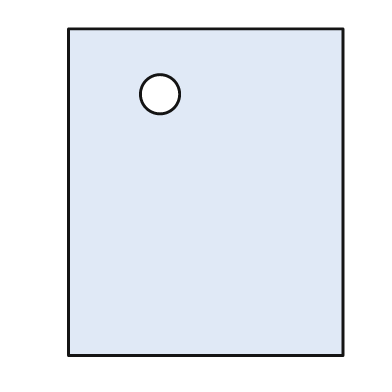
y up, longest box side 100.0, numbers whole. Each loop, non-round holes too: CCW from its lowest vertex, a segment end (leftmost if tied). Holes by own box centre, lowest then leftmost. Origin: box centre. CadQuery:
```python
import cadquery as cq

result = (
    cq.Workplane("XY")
    .moveTo(-42.0, -50.0)
    .lineTo(42.0, -50.0)
    .lineTo(42.0, 50.0)
    .lineTo(-42.0, 50.0)
    .close()
    .moveTo(-14.0, 30.0)
    .circle(6.0)
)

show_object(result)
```